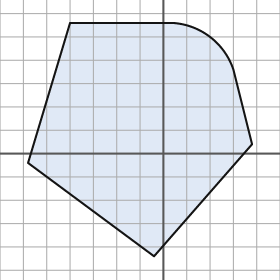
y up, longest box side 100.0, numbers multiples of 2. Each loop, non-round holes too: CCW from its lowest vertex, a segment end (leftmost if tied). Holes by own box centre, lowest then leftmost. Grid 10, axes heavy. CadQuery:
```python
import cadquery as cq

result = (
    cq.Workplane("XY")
    .moveTo(-4.0, -44.0)
    .lineTo(38.0, 4.0)
    .lineTo(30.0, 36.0)
    .threePointArc((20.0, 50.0), (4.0, 56.0))
    .lineTo(-40.0, 56.0)
    .lineTo(-58.0, -4.0)
    .close()
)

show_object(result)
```